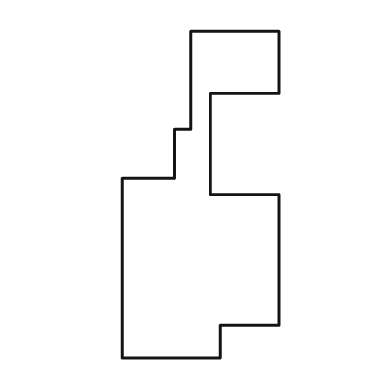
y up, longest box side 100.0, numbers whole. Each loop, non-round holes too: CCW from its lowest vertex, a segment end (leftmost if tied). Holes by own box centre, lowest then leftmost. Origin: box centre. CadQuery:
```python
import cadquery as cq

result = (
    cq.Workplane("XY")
    .moveTo(-24.0, -50.0)
    .lineTo(6.0, -50.0)
    .lineTo(6.0, -40.0)
    .lineTo(24.0, -40.0)
    .lineTo(24.0, 0.0)
    .lineTo(3.0, 0.0)
    .lineTo(3.0, 31.0)
    .lineTo(24.0, 31.0)
    .lineTo(24.0, 50.0)
    .lineTo(-3.0, 50.0)
    .lineTo(-3.0, 20.0)
    .lineTo(-8.0, 20.0)
    .lineTo(-8.0, 5.0)
    .lineTo(-24.0, 5.0)
    .close()
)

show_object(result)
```